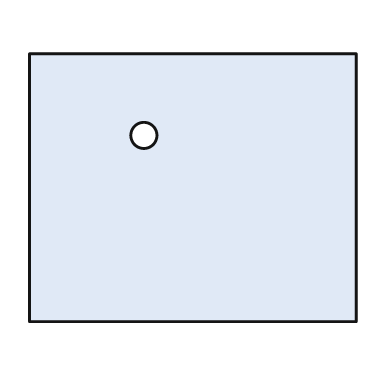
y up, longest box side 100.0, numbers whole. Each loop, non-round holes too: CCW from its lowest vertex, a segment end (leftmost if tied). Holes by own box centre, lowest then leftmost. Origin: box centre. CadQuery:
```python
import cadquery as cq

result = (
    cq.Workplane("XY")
    .moveTo(-50.0, -41.0)
    .lineTo(50.0, -41.0)
    .lineTo(50.0, 41.0)
    .lineTo(-50.0, 41.0)
    .close()
    .moveTo(-15.0, 16.0)
    .circle(4.0)
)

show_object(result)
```